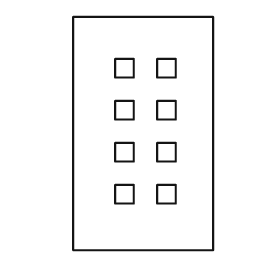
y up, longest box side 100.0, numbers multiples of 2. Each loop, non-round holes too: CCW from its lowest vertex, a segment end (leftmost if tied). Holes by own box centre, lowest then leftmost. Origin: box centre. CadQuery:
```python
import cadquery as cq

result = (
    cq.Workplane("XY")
    .moveTo(-30.0, -50.0)
    .lineTo(30.0, -50.0)
    .lineTo(30.0, 50.0)
    .lineTo(-30.0, 50.0)
    .close()
    .moveTo(-12.0, -30.0)
    .lineTo(-4.0, -30.0)
    .lineTo(-4.0, -22.0)
    .lineTo(-12.0, -22.0)
    .close()
    .moveTo(6.0, -30.0)
    .lineTo(14.0, -30.0)
    .lineTo(14.0, -22.0)
    .lineTo(6.0, -22.0)
    .close()
    .moveTo(-12.0, -12.0)
    .lineTo(-4.0, -12.0)
    .lineTo(-4.0, -4.0)
    .lineTo(-12.0, -4.0)
    .close()
    .moveTo(6.0, -12.0)
    .lineTo(14.0, -12.0)
    .lineTo(14.0, -4.0)
    .lineTo(6.0, -4.0)
    .close()
    .moveTo(-12.0, 6.0)
    .lineTo(-4.0, 6.0)
    .lineTo(-4.0, 14.0)
    .lineTo(-12.0, 14.0)
    .close()
    .moveTo(6.0, 6.0)
    .lineTo(14.0, 6.0)
    .lineTo(14.0, 14.0)
    .lineTo(6.0, 14.0)
    .close()
    .moveTo(-12.0, 24.0)
    .lineTo(-4.0, 24.0)
    .lineTo(-4.0, 32.0)
    .lineTo(-12.0, 32.0)
    .close()
    .moveTo(6.0, 24.0)
    .lineTo(14.0, 24.0)
    .lineTo(14.0, 32.0)
    .lineTo(6.0, 32.0)
    .close()
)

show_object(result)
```